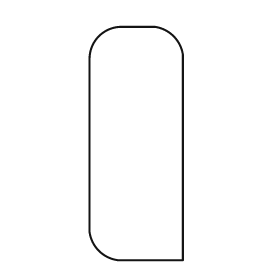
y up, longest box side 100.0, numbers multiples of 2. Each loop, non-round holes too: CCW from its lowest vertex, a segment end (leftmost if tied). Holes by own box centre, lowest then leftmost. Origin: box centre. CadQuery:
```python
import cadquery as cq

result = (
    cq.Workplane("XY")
    .moveTo(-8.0, -50.0)
    .lineTo(20.0, -50.0)
    .lineTo(20.0, 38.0)
    .threePointArc((16.0, 46.0), (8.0, 50.0))
    .lineTo(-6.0, 50.0)
    .threePointArc((-16.0, 46.0), (-20.0, 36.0))
    .lineTo(-20.0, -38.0)
    .threePointArc((-16.0, -46.0), (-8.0, -50.0))
    .close()
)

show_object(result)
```